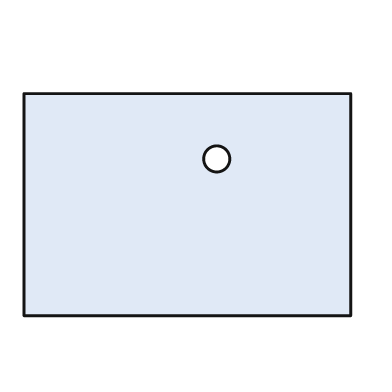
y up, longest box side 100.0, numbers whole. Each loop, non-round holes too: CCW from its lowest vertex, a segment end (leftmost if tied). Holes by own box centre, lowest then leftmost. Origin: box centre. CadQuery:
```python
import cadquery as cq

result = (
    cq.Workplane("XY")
    .moveTo(-50.0, -34.0)
    .lineTo(50.0, -34.0)
    .lineTo(50.0, 34.0)
    .lineTo(-50.0, 34.0)
    .close()
    .moveTo(9.0, 14.0)
    .circle(4.0)
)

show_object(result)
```